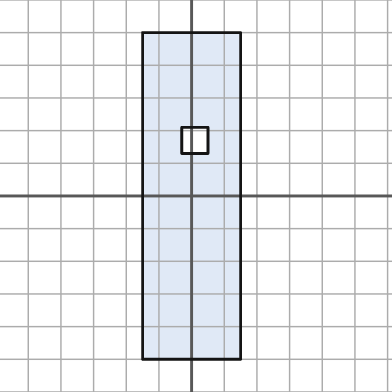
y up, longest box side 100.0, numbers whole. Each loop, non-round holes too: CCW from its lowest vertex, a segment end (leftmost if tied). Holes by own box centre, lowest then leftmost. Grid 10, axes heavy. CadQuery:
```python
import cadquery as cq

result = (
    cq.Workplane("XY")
    .moveTo(-15.0, -50.0)
    .lineTo(15.0, -50.0)
    .lineTo(15.0, 50.0)
    .lineTo(-15.0, 50.0)
    .close()
    .moveTo(-3.0, 13.0)
    .lineTo(5.0, 13.0)
    .lineTo(5.0, 21.0)
    .lineTo(-3.0, 21.0)
    .close()
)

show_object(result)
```